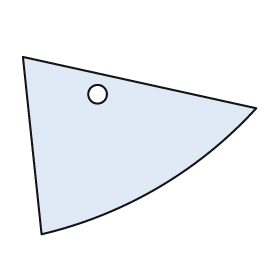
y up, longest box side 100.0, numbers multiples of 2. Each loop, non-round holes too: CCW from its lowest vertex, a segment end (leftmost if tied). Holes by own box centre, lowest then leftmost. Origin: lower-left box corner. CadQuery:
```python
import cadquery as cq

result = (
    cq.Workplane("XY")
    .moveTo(8.0, 0.0)
    .threePointArc((58.0, 20.0), (100.0, 54.0))
    .lineTo(0.0, 76.0)
    .close()
    .moveTo(32.0, 60.0)
    .circle(4.0)
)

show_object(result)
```